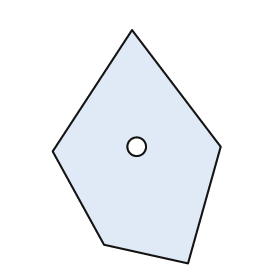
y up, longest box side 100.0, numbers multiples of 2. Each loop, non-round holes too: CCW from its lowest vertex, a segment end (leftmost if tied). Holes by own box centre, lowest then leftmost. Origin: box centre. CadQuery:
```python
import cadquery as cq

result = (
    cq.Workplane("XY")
    .moveTo(22.0, -50.0)
    .lineTo(36.0, 0.0)
    .lineTo(-2.0, 50.0)
    .lineTo(-36.0, -2.0)
    .lineTo(-14.0, -42.0)
    .close()
    .moveTo(0.0, 0.0)
    .circle(4.0)
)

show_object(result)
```